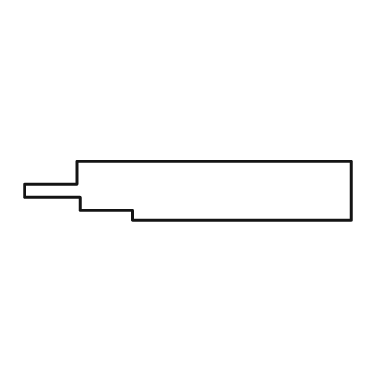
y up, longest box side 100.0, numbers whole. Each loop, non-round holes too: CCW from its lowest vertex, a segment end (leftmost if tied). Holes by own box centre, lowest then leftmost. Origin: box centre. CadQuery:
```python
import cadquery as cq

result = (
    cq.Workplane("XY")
    .moveTo(-17.0, -9.0)
    .lineTo(50.0, -9.0)
    .lineTo(50.0, 9.0)
    .lineTo(-34.0, 9.0)
    .lineTo(-34.0, 2.0)
    .lineTo(-50.0, 2.0)
    .lineTo(-50.0, -2.0)
    .lineTo(-33.0, -2.0)
    .lineTo(-33.0, -6.0)
    .lineTo(-17.0, -6.0)
    .close()
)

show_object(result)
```